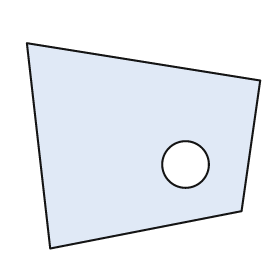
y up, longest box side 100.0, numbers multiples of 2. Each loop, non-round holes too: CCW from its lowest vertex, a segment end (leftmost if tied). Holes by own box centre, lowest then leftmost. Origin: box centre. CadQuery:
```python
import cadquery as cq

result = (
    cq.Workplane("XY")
    .moveTo(-40.0, -44.0)
    .lineTo(42.0, -28.0)
    .lineTo(50.0, 28.0)
    .lineTo(-50.0, 44.0)
    .close()
    .moveTo(18.0, -8.0)
    .circle(10.0)
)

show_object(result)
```